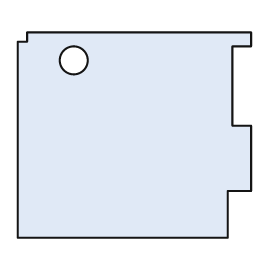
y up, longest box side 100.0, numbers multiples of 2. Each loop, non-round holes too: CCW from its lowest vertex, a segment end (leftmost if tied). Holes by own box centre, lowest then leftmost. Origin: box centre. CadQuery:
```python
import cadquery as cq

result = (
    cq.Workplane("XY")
    .moveTo(-50.0, -44.0)
    .lineTo(40.0, -44.0)
    .lineTo(40.0, -24.0)
    .lineTo(50.0, -24.0)
    .lineTo(50.0, 4.0)
    .lineTo(42.0, 4.0)
    .lineTo(42.0, 38.0)
    .lineTo(50.0, 38.0)
    .lineTo(50.0, 44.0)
    .lineTo(-46.0, 44.0)
    .lineTo(-46.0, 40.0)
    .lineTo(-50.0, 40.0)
    .close()
    .moveTo(-26.0, 32.0)
    .circle(6.0)
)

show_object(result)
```